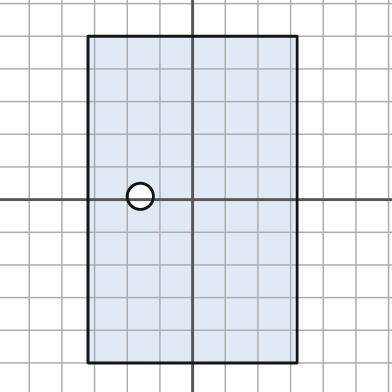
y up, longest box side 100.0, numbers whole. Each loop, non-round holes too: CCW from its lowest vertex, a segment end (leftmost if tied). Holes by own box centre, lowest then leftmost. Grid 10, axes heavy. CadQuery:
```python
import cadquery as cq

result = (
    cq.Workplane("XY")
    .moveTo(-32.0, -50.0)
    .lineTo(32.0, -50.0)
    .lineTo(32.0, 50.0)
    .lineTo(-32.0, 50.0)
    .close()
    .moveTo(-16.0, 1.0)
    .circle(4.0)
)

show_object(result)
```